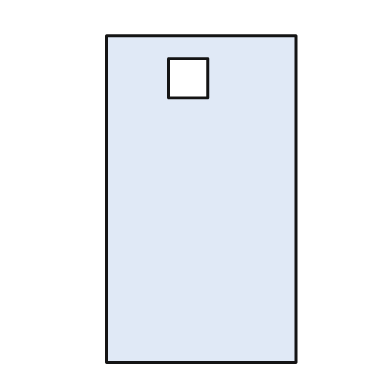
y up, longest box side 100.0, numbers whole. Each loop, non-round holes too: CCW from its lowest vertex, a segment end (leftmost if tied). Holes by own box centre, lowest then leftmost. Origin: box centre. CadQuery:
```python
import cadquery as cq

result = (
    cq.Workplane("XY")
    .moveTo(-29.0, -50.0)
    .lineTo(29.0, -50.0)
    .lineTo(29.0, 50.0)
    .lineTo(-29.0, 50.0)
    .close()
    .moveTo(-10.0, 31.0)
    .lineTo(2.0, 31.0)
    .lineTo(2.0, 43.0)
    .lineTo(-10.0, 43.0)
    .close()
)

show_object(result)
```